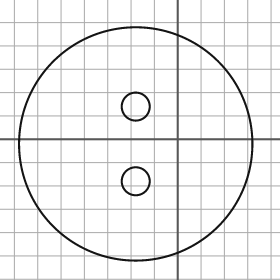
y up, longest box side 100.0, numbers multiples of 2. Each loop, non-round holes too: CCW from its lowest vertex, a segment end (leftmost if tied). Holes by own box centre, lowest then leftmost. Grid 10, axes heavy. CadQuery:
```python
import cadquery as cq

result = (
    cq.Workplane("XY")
    .moveTo(-18.0, -2.0)
    .circle(50.0)
    .moveTo(-18.0, -18.0)
    .circle(6.0)
    .moveTo(-18.0, 14.0)
    .circle(6.0)
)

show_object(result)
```